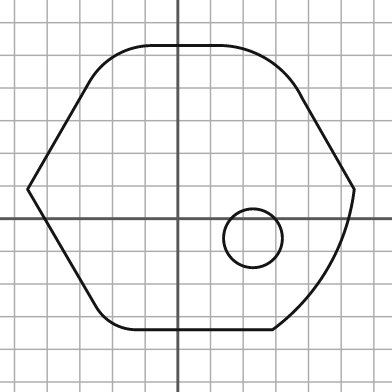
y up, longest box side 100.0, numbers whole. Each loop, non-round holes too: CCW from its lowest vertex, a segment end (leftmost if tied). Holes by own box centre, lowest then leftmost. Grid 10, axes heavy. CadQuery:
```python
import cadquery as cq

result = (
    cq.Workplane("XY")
    .moveTo(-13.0, -34.0)
    .lineTo(29.0, -34.0)
    .threePointArc((46.0, -15.0), (54.0, 9.0))
    .lineTo(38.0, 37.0)
    .threePointArc((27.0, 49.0), (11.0, 53.0))
    .lineTo(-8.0, 53.0)
    .threePointArc((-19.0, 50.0), (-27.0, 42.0))
    .lineTo(-46.0, 9.0)
    .lineTo(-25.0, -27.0)
    .threePointArc((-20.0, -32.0), (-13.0, -34.0))
    .close()
    .moveTo(23.0, -6.0)
    .circle(9.0)
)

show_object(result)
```